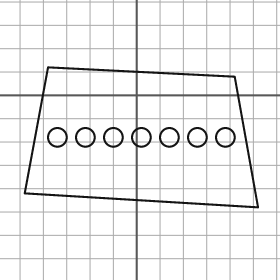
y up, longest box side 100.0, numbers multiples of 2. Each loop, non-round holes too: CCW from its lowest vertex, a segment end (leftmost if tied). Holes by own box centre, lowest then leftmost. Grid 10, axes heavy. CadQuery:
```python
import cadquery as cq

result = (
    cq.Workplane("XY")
    .moveTo(52.0, -48.0)
    .lineTo(42.0, 8.0)
    .lineTo(-38.0, 12.0)
    .lineTo(-48.0, -42.0)
    .close()
    .moveTo(-34.0, -18.0)
    .circle(4.0)
    .moveTo(-22.0, -18.0)
    .circle(4.0)
    .moveTo(-10.0, -18.0)
    .circle(4.0)
    .moveTo(2.0, -18.0)
    .circle(4.0)
    .moveTo(14.0, -18.0)
    .circle(4.0)
    .moveTo(26.0, -18.0)
    .circle(4.0)
    .moveTo(38.0, -18.0)
    .circle(4.0)
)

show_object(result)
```